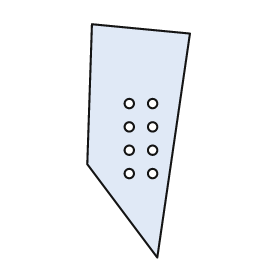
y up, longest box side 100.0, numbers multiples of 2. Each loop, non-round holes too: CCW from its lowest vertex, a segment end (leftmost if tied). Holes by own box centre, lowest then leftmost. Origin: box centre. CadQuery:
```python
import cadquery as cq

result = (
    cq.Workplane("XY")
    .moveTo(8.0, -50.0)
    .lineTo(22.0, 46.0)
    .lineTo(-20.0, 50.0)
    .lineTo(-22.0, -10.0)
    .close()
    .moveTo(-4.0, -14.0)
    .circle(2.0)
    .moveTo(6.0, -14.0)
    .circle(2.0)
    .moveTo(-4.0, -4.0)
    .circle(2.0)
    .moveTo(6.0, -4.0)
    .circle(2.0)
    .moveTo(-4.0, 6.0)
    .circle(2.0)
    .moveTo(6.0, 6.0)
    .circle(2.0)
    .moveTo(-4.0, 16.0)
    .circle(2.0)
    .moveTo(6.0, 16.0)
    .circle(2.0)
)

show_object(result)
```